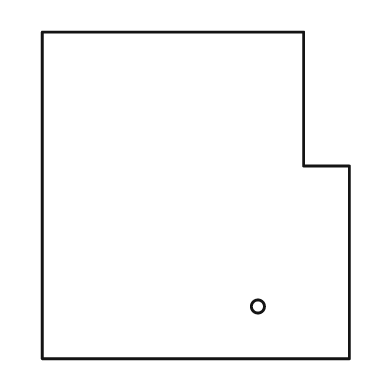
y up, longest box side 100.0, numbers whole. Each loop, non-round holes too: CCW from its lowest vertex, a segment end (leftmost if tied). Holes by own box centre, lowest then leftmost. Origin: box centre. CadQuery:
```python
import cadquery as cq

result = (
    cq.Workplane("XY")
    .moveTo(-47.0, -50.0)
    .lineTo(47.0, -50.0)
    .lineTo(47.0, 9.0)
    .lineTo(33.0, 9.0)
    .lineTo(33.0, 50.0)
    .lineTo(-47.0, 50.0)
    .close()
    .moveTo(19.0, -34.0)
    .circle(2.0)
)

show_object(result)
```